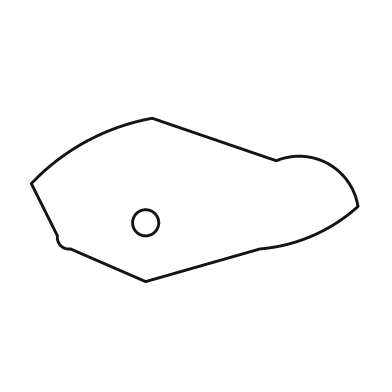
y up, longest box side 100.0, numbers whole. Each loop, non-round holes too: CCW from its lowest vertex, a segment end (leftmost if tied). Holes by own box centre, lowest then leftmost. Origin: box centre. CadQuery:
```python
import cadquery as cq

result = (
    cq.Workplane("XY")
    .moveTo(-15.0, -25.0)
    .lineTo(20.0, -15.0)
    .threePointArc((36.0, -11.0), (50.0, -2.0))
    .threePointArc((41.0, 11.0), (25.0, 12.0))
    .lineTo(-13.0, 25.0)
    .threePointArc((-33.0, 18.0), (-50.0, 5.0))
    .lineTo(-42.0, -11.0)
    .threePointArc((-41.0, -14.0), (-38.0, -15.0))
    .close()
    .moveTo(-15.0, -7.0)
    .circle(4.0)
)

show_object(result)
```